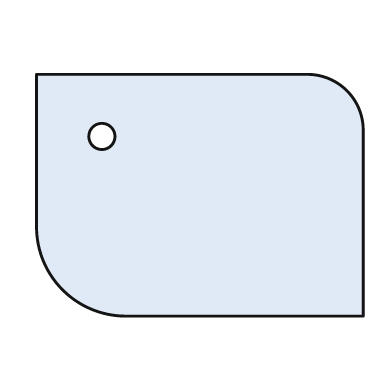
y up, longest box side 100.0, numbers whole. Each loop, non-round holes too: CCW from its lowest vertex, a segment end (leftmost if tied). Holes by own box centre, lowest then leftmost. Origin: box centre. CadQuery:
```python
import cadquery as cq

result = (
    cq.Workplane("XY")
    .moveTo(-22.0, -37.0)
    .lineTo(50.0, -37.0)
    .lineTo(50.0, 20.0)
    .threePointArc((45.0, 32.0), (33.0, 37.0))
    .lineTo(-50.0, 37.0)
    .lineTo(-50.0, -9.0)
    .threePointArc((-42.0, -29.0), (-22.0, -37.0))
    .close()
    .moveTo(-30.0, 18.0)
    .circle(4.0)
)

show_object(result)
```